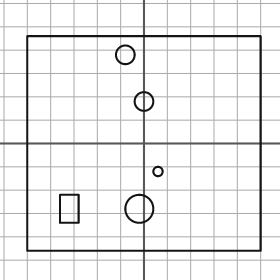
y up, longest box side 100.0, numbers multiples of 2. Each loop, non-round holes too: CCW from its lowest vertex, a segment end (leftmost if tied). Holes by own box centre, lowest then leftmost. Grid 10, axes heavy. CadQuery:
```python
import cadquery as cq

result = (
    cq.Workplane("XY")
    .moveTo(-50.0, -46.0)
    .lineTo(50.0, -46.0)
    .lineTo(50.0, 46.0)
    .lineTo(-50.0, 46.0)
    .close()
    .moveTo(-36.0, -34.0)
    .lineTo(-28.0, -34.0)
    .lineTo(-28.0, -22.0)
    .lineTo(-36.0, -22.0)
    .close()
    .moveTo(-2.0, -28.0)
    .circle(6.0)
    .moveTo(6.0, -12.0)
    .circle(2.0)
    .moveTo(0.0, 18.0)
    .circle(4.0)
    .moveTo(-8.0, 38.0)
    .circle(4.0)
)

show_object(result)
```